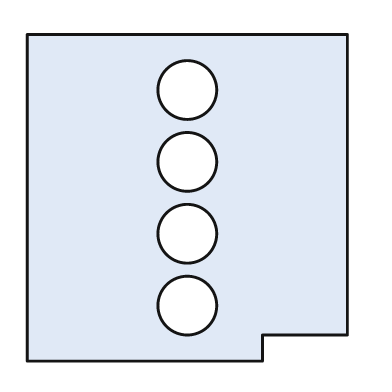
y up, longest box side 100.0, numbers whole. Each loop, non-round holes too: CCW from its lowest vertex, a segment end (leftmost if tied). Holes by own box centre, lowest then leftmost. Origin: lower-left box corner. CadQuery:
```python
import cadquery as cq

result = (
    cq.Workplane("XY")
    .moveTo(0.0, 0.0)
    .lineTo(72.0, 0.0)
    .lineTo(72.0, 8.0)
    .lineTo(98.0, 8.0)
    .lineTo(98.0, 100.0)
    .lineTo(0.0, 100.0)
    .close()
    .moveTo(49.0, 17.0)
    .circle(9.0)
    .moveTo(49.0, 39.0)
    .circle(9.0)
    .moveTo(49.0, 61.0)
    .circle(9.0)
    .moveTo(49.0, 83.0)
    .circle(9.0)
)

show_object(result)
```